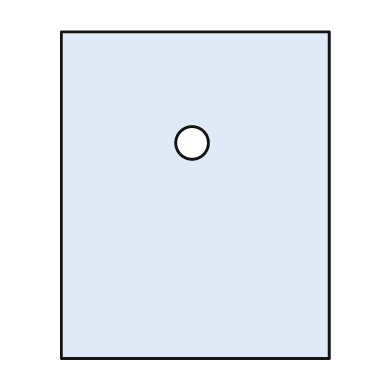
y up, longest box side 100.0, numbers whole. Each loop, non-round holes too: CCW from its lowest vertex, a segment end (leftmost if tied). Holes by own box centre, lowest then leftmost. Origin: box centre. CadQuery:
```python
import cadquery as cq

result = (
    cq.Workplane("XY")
    .moveTo(-41.0, -50.0)
    .lineTo(41.0, -50.0)
    .lineTo(41.0, 50.0)
    .lineTo(-41.0, 50.0)
    .close()
    .moveTo(-1.0, 16.0)
    .circle(5.0)
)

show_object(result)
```